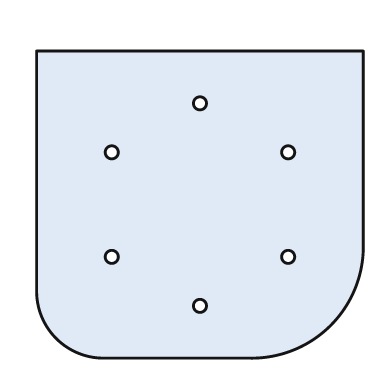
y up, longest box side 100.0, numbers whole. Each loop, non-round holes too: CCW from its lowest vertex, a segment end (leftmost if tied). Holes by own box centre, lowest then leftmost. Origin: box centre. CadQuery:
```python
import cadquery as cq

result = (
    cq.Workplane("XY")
    .moveTo(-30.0, -47.0)
    .lineTo(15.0, -47.0)
    .threePointArc((40.0, -37.0), (50.0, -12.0))
    .lineTo(50.0, 47.0)
    .lineTo(-50.0, 47.0)
    .lineTo(-50.0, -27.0)
    .threePointArc((-44.0, -41.0), (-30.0, -47.0))
    .close()
    .moveTo(0.0, -31.0)
    .circle(2.0)
    .moveTo(-27.0, -16.0)
    .circle(2.0)
    .moveTo(27.0, -16.0)
    .circle(2.0)
    .moveTo(-27.0, 16.0)
    .circle(2.0)
    .moveTo(27.0, 16.0)
    .circle(2.0)
    .moveTo(0.0, 31.0)
    .circle(2.0)
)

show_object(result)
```